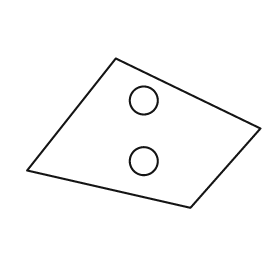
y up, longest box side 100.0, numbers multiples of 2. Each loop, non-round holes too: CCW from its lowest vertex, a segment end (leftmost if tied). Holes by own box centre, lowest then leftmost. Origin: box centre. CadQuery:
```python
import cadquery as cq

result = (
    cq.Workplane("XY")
    .moveTo(20.0, -32.0)
    .lineTo(50.0, 2.0)
    .lineTo(-12.0, 32.0)
    .lineTo(-50.0, -16.0)
    .close()
    .moveTo(0.0, -12.0)
    .circle(6.0)
    .moveTo(0.0, 14.0)
    .circle(6.0)
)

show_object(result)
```